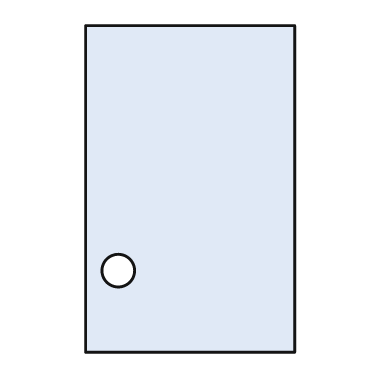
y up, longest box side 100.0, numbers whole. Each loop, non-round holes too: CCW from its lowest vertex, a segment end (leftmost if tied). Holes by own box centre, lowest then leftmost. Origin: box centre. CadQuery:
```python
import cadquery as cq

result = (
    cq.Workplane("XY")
    .moveTo(-32.0, -50.0)
    .lineTo(32.0, -50.0)
    .lineTo(32.0, 50.0)
    .lineTo(-32.0, 50.0)
    .close()
    .moveTo(-22.0, -25.0)
    .circle(5.0)
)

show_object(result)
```